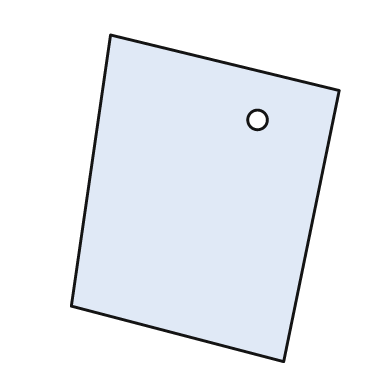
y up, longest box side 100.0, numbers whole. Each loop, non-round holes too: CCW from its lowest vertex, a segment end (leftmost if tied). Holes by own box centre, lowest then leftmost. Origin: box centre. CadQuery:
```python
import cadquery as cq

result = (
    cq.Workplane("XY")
    .moveTo(24.0, -50.0)
    .lineTo(41.0, 33.0)
    .lineTo(-29.0, 50.0)
    .lineTo(-41.0, -33.0)
    .close()
    .moveTo(16.0, 24.0)
    .circle(3.0)
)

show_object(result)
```